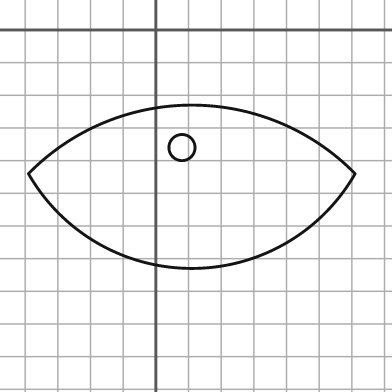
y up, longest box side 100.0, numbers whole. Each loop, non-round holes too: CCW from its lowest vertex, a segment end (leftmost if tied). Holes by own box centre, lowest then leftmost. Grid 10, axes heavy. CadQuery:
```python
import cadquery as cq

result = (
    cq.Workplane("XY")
    .moveTo(-39.0, -44.0)
    .threePointArc((11.0, -73.0), (61.0, -44.0))
    .threePointArc((11.0, -23.0), (-39.0, -44.0))
    .close()
    .moveTo(8.0, -36.0)
    .circle(4.0)
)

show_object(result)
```